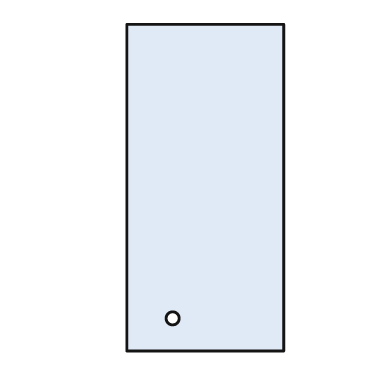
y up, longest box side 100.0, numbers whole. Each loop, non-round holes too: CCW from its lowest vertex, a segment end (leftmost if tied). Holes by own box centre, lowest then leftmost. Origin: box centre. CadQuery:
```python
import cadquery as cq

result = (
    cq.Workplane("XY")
    .moveTo(-24.0, -50.0)
    .lineTo(24.0, -50.0)
    .lineTo(24.0, 50.0)
    .lineTo(-24.0, 50.0)
    .close()
    .moveTo(-10.0, -40.0)
    .circle(2.0)
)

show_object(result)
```